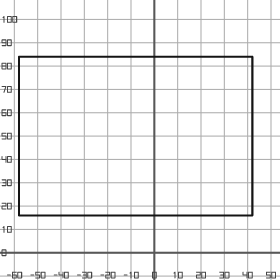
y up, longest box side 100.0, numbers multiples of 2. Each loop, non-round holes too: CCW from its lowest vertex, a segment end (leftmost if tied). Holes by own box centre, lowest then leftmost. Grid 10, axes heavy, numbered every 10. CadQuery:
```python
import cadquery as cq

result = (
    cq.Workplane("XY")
    .moveTo(-58.0, 16.0)
    .lineTo(42.0, 16.0)
    .lineTo(42.0, 84.0)
    .lineTo(-58.0, 84.0)
    .close()
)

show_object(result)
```